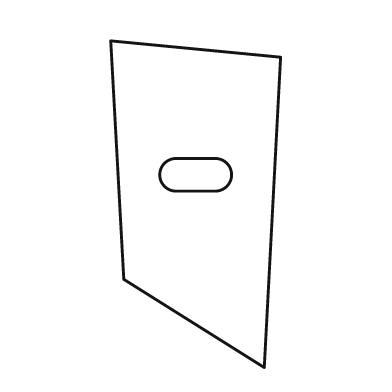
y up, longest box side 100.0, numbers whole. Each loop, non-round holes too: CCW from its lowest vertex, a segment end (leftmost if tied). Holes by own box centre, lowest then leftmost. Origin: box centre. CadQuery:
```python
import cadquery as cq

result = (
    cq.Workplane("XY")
    .moveTo(21.0, -50.0)
    .lineTo(26.0, 45.0)
    .lineTo(-26.0, 50.0)
    .lineTo(-22.0, -23.0)
    .close()
    .moveTo(-6.0, 4.0)
    .lineTo(6.0, 4.0)
    .threePointArc((11.0, 9.0), (6.0, 14.0))
    .lineTo(-6.0, 14.0)
    .threePointArc((-11.0, 9.0), (-6.0, 4.0))
    .close()
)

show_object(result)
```